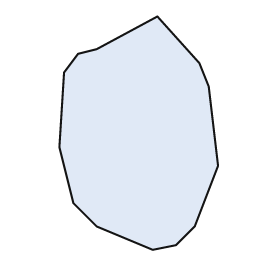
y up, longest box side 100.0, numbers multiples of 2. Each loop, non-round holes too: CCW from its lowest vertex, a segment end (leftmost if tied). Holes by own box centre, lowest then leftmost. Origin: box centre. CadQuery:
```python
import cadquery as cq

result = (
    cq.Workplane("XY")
    .moveTo(6.0, -50.0)
    .lineTo(16.0, -48.0)
    .lineTo(24.0, -40.0)
    .lineTo(34.0, -14.0)
    .lineTo(30.0, 20.0)
    .lineTo(26.0, 30.0)
    .lineTo(8.0, 50.0)
    .lineTo(-18.0, 36.0)
    .lineTo(-26.0, 34.0)
    .lineTo(-32.0, 26.0)
    .lineTo(-34.0, -6.0)
    .lineTo(-28.0, -30.0)
    .lineTo(-18.0, -40.0)
    .close()
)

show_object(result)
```